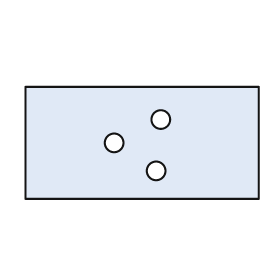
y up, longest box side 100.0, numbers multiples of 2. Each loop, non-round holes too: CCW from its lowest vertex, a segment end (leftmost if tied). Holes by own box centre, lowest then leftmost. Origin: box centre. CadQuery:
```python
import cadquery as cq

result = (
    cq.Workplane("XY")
    .moveTo(-50.0, -24.0)
    .lineTo(50.0, -24.0)
    .lineTo(50.0, 24.0)
    .lineTo(-50.0, 24.0)
    .close()
    .moveTo(6.0, -12.0)
    .circle(4.0)
    .moveTo(-12.0, 0.0)
    .circle(4.0)
    .moveTo(8.0, 10.0)
    .circle(4.0)
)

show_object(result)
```